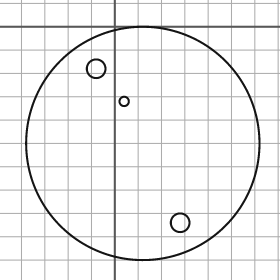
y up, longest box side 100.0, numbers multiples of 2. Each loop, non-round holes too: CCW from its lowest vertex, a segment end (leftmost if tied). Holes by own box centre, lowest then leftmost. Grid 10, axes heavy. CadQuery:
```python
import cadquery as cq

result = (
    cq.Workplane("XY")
    .moveTo(12.0, -50.0)
    .circle(50.0)
    .moveTo(28.0, -84.0)
    .circle(4.0)
    .moveTo(4.0, -32.0)
    .circle(2.0)
    .moveTo(-8.0, -18.0)
    .circle(4.0)
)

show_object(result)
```